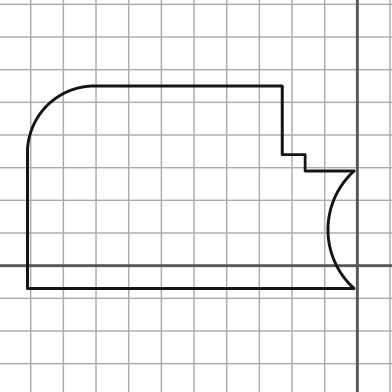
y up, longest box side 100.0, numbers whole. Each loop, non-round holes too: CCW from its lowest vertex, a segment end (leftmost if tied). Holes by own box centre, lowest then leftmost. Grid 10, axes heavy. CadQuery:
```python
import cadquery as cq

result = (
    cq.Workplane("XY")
    .moveTo(-101.0, -7.0)
    .lineTo(-1.0, -7.0)
    .threePointArc((-9.0, 11.0), (-1.0, 29.0))
    .lineTo(-16.0, 29.0)
    .lineTo(-16.0, 34.0)
    .lineTo(-23.0, 34.0)
    .lineTo(-23.0, 55.0)
    .lineTo(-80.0, 55.0)
    .threePointArc((-95.0, 49.0), (-101.0, 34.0))
    .close()
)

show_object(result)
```